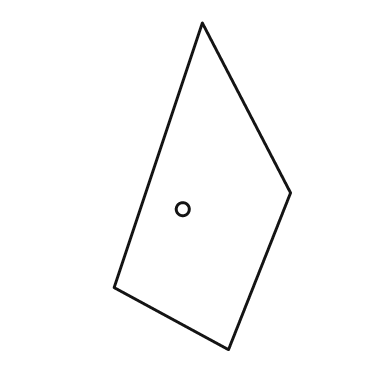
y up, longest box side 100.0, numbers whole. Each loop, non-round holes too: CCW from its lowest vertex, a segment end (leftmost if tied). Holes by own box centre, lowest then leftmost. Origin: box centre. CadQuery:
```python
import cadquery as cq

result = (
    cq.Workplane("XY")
    .moveTo(8.0, -50.0)
    .lineTo(27.0, -2.0)
    .lineTo(0.0, 50.0)
    .lineTo(-27.0, -31.0)
    .close()
    .moveTo(-6.0, -7.0)
    .circle(2.0)
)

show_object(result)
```